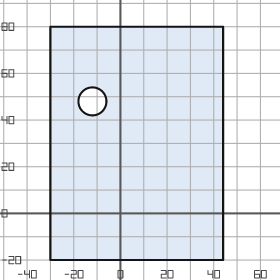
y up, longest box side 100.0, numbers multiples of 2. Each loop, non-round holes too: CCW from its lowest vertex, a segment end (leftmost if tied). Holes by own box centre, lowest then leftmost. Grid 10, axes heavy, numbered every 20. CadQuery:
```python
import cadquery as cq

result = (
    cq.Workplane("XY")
    .moveTo(-30.0, -20.0)
    .lineTo(44.0, -20.0)
    .lineTo(44.0, 80.0)
    .lineTo(-30.0, 80.0)
    .close()
    .moveTo(-12.0, 48.0)
    .circle(6.0)
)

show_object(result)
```